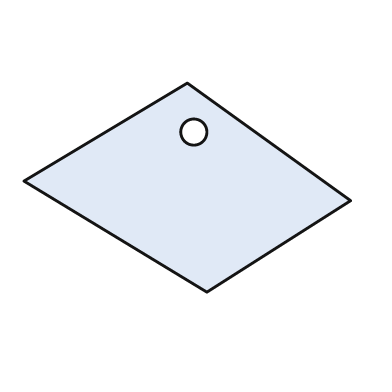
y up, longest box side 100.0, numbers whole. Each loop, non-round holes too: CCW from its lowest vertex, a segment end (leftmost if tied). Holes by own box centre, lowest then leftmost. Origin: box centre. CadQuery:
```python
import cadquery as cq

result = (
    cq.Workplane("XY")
    .moveTo(6.0, -32.0)
    .lineTo(50.0, -4.0)
    .lineTo(0.0, 32.0)
    .lineTo(-50.0, 2.0)
    .close()
    .moveTo(2.0, 17.0)
    .circle(4.0)
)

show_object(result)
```